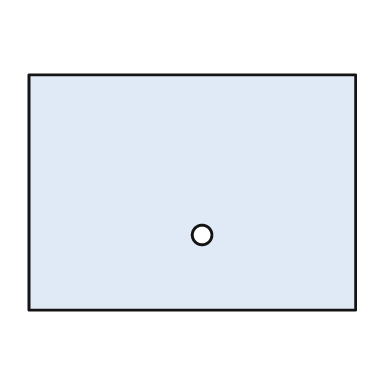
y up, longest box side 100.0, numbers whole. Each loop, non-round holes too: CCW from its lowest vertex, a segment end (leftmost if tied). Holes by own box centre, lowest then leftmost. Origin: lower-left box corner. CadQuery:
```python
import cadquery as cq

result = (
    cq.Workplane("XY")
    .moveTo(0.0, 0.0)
    .lineTo(100.0, 0.0)
    .lineTo(100.0, 72.0)
    .lineTo(0.0, 72.0)
    .close()
    .moveTo(53.0, 23.0)
    .circle(3.0)
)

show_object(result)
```